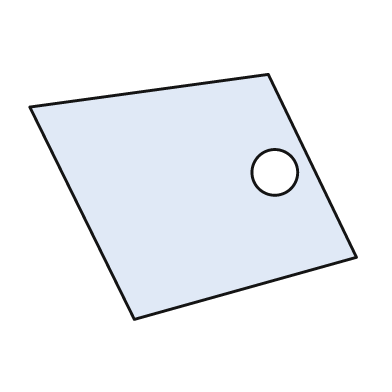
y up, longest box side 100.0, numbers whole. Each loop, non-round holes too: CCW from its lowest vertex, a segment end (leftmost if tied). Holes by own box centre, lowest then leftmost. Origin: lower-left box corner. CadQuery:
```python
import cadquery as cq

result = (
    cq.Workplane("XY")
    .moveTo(32.0, 0.0)
    .lineTo(100.0, 19.0)
    .lineTo(73.0, 75.0)
    .lineTo(0.0, 65.0)
    .close()
    .moveTo(75.0, 45.0)
    .circle(7.0)
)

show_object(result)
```